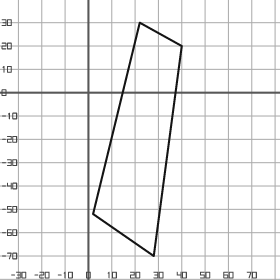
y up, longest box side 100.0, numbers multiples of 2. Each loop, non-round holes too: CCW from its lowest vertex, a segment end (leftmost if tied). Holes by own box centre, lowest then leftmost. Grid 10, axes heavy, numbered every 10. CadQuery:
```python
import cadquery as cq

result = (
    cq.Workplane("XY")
    .moveTo(28.0, -70.0)
    .lineTo(40.0, 20.0)
    .lineTo(22.0, 30.0)
    .lineTo(2.0, -52.0)
    .close()
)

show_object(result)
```